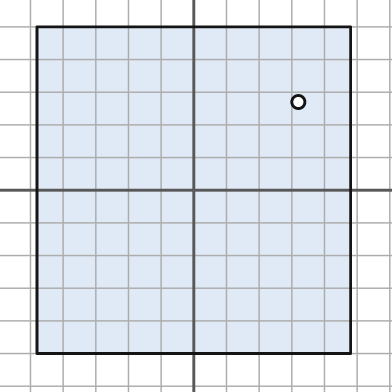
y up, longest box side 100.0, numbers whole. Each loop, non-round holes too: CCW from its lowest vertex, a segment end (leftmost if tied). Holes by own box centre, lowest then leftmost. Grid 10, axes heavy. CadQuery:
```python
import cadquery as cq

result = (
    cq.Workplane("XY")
    .moveTo(-48.0, -50.0)
    .lineTo(48.0, -50.0)
    .lineTo(48.0, 50.0)
    .lineTo(-48.0, 50.0)
    .close()
    .moveTo(32.0, 27.0)
    .circle(2.0)
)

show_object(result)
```